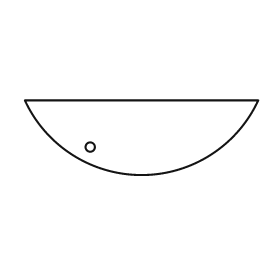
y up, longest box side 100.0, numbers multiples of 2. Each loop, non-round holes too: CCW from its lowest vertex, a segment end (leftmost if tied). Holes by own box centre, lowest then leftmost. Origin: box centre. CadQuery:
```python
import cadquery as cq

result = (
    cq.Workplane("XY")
    .moveTo(-50.0, 16.0)
    .threePointArc((0.0, -16.0), (50.0, 16.0))
    .close()
    .moveTo(-22.0, -4.0)
    .circle(2.0)
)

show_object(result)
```